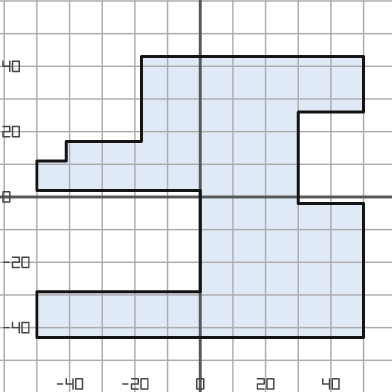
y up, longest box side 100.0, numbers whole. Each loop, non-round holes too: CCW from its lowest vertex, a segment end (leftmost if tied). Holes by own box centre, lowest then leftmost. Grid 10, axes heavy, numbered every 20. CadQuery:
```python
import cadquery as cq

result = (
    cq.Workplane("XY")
    .moveTo(-50.0, -43.0)
    .lineTo(50.0, -43.0)
    .lineTo(50.0, -2.0)
    .lineTo(30.0, -2.0)
    .lineTo(30.0, 26.0)
    .lineTo(50.0, 26.0)
    .lineTo(50.0, 43.0)
    .lineTo(-18.0, 43.0)
    .lineTo(-18.0, 17.0)
    .lineTo(-41.0, 17.0)
    .lineTo(-41.0, 11.0)
    .lineTo(-50.0, 11.0)
    .lineTo(-50.0, 2.0)
    .lineTo(0.0, 2.0)
    .lineTo(0.0, -29.0)
    .lineTo(-50.0, -29.0)
    .close()
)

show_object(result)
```